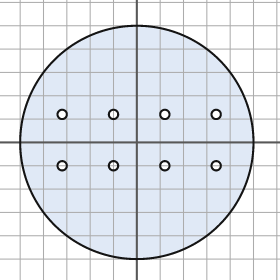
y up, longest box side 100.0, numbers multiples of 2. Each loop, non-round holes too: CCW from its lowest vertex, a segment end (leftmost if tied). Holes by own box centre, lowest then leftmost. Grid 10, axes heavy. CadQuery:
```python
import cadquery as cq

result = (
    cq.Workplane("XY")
    .moveTo(0.0, 0.0)
    .circle(50.0)
    .moveTo(-32.0, -10.0)
    .circle(2.0)
    .moveTo(-10.0, -10.0)
    .circle(2.0)
    .moveTo(12.0, -10.0)
    .circle(2.0)
    .moveTo(34.0, -10.0)
    .circle(2.0)
    .moveTo(-32.0, 12.0)
    .circle(2.0)
    .moveTo(-10.0, 12.0)
    .circle(2.0)
    .moveTo(12.0, 12.0)
    .circle(2.0)
    .moveTo(34.0, 12.0)
    .circle(2.0)
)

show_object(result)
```